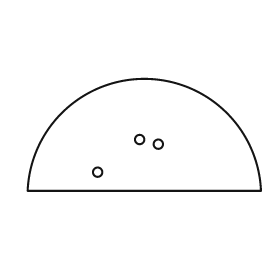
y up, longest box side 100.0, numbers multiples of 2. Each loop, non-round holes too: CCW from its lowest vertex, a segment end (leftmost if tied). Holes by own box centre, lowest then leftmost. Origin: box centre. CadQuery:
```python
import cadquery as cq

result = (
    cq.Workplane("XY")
    .moveTo(-50.0, -24.0)
    .lineTo(50.0, -24.0)
    .threePointArc((0.0, 24.0), (-50.0, -24.0))
    .close()
    .moveTo(-20.0, -16.0)
    .circle(2.0)
    .moveTo(6.0, -4.0)
    .circle(2.0)
    .moveTo(-2.0, -2.0)
    .circle(2.0)
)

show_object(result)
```